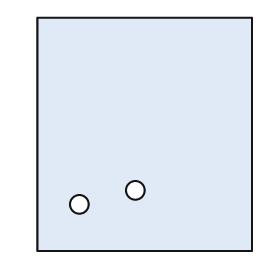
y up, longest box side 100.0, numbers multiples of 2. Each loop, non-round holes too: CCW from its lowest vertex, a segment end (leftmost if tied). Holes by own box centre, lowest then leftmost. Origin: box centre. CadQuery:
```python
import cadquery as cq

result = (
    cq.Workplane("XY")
    .moveTo(-46.0, -50.0)
    .lineTo(46.0, -50.0)
    .lineTo(46.0, 50.0)
    .lineTo(-46.0, 50.0)
    .close()
    .moveTo(-28.0, -30.0)
    .circle(4.0)
    .moveTo(-4.0, -24.0)
    .circle(4.0)
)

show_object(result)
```